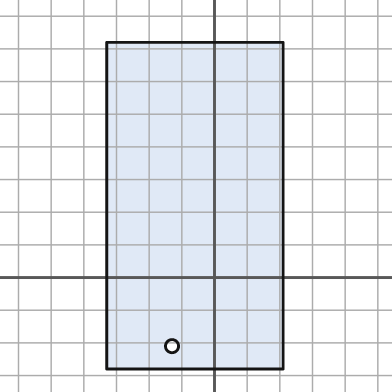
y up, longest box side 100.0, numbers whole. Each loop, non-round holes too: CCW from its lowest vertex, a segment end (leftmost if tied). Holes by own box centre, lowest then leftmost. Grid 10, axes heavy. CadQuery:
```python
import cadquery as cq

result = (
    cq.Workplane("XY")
    .moveTo(-33.0, -28.0)
    .lineTo(21.0, -28.0)
    .lineTo(21.0, 72.0)
    .lineTo(-33.0, 72.0)
    .close()
    .moveTo(-13.0, -21.0)
    .circle(2.0)
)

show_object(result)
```